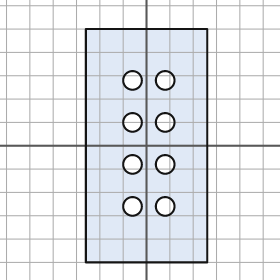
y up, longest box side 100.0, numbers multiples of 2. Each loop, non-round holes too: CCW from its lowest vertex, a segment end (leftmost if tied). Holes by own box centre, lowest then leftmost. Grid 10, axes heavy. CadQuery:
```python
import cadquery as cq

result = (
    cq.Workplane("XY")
    .moveTo(-26.0, -50.0)
    .lineTo(26.0, -50.0)
    .lineTo(26.0, 50.0)
    .lineTo(-26.0, 50.0)
    .close()
    .moveTo(-6.0, -26.0)
    .circle(4.0)
    .moveTo(8.0, -26.0)
    .circle(4.0)
    .moveTo(-6.0, -8.0)
    .circle(4.0)
    .moveTo(8.0, -8.0)
    .circle(4.0)
    .moveTo(-6.0, 10.0)
    .circle(4.0)
    .moveTo(8.0, 10.0)
    .circle(4.0)
    .moveTo(-6.0, 28.0)
    .circle(4.0)
    .moveTo(8.0, 28.0)
    .circle(4.0)
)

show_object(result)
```